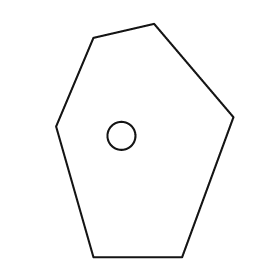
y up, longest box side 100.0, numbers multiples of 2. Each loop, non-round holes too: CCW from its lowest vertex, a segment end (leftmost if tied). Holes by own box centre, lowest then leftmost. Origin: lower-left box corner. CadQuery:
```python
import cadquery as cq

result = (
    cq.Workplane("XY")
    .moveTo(16.0, 0.0)
    .lineTo(54.0, 0.0)
    .lineTo(76.0, 60.0)
    .lineTo(42.0, 100.0)
    .lineTo(16.0, 94.0)
    .lineTo(0.0, 56.0)
    .close()
    .moveTo(28.0, 52.0)
    .circle(6.0)
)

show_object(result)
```